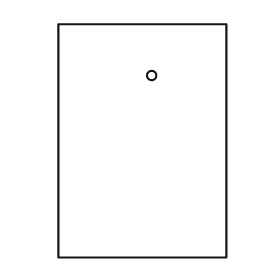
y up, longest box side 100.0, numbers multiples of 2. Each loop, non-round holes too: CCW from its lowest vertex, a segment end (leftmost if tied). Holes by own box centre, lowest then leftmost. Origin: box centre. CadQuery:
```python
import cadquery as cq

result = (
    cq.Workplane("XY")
    .moveTo(-36.0, -50.0)
    .lineTo(36.0, -50.0)
    .lineTo(36.0, 50.0)
    .lineTo(-36.0, 50.0)
    .close()
    .moveTo(4.0, 28.0)
    .circle(2.0)
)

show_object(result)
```